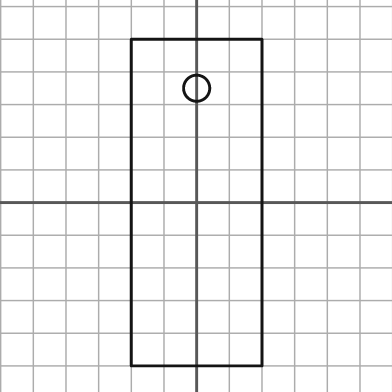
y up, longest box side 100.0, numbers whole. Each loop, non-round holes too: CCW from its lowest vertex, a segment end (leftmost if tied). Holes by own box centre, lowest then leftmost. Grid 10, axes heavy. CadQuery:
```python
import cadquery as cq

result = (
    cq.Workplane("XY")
    .moveTo(-20.0, -50.0)
    .lineTo(20.0, -50.0)
    .lineTo(20.0, 50.0)
    .lineTo(-20.0, 50.0)
    .close()
    .moveTo(0.0, 35.0)
    .circle(4.0)
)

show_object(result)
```